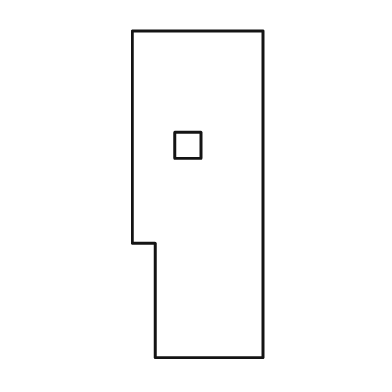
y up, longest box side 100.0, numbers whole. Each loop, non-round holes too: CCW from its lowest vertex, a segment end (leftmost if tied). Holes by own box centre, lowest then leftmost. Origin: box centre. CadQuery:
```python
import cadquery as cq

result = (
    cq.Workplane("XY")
    .moveTo(-13.0, -50.0)
    .lineTo(20.0, -50.0)
    .lineTo(20.0, 50.0)
    .lineTo(-20.0, 50.0)
    .lineTo(-20.0, -15.0)
    .lineTo(-13.0, -15.0)
    .close()
    .moveTo(-7.0, 11.0)
    .lineTo(1.0, 11.0)
    .lineTo(1.0, 19.0)
    .lineTo(-7.0, 19.0)
    .close()
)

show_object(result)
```